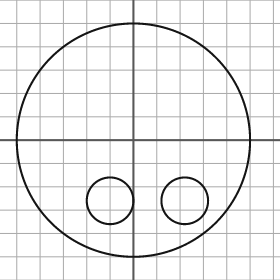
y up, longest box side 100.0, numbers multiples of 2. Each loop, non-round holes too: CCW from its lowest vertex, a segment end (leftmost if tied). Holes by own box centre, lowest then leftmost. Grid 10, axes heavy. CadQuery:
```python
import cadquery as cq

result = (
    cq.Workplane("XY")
    .moveTo(0.0, 0.0)
    .circle(50.0)
    .moveTo(-10.0, -26.0)
    .circle(10.0)
    .moveTo(22.0, -26.0)
    .circle(10.0)
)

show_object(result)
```